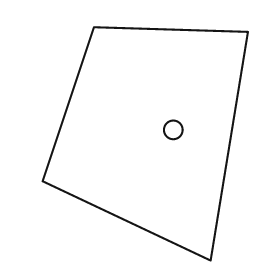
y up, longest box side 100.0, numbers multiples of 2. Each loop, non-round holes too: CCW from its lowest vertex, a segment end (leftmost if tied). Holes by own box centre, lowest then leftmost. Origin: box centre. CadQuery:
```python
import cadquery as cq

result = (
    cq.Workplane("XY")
    .moveTo(28.0, -50.0)
    .lineTo(44.0, 48.0)
    .lineTo(-22.0, 50.0)
    .lineTo(-44.0, -16.0)
    .close()
    .moveTo(12.0, 6.0)
    .circle(4.0)
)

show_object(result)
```